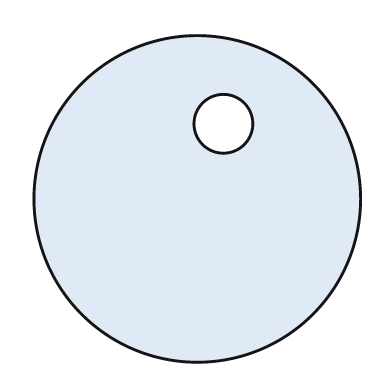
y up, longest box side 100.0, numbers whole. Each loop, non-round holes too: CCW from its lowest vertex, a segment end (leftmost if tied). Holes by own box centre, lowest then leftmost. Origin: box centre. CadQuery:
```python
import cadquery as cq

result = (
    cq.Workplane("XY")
    .moveTo(0.0, 0.0)
    .circle(50.0)
    .moveTo(8.0, 23.0)
    .circle(9.0)
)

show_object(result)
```